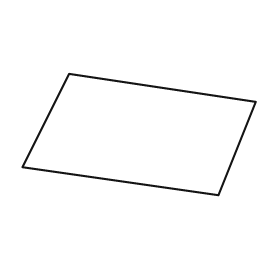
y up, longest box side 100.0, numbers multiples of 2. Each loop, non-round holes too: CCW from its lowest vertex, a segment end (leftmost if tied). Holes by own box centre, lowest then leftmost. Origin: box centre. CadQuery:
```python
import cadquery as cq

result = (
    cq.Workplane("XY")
    .moveTo(34.0, -26.0)
    .lineTo(50.0, 14.0)
    .lineTo(-30.0, 26.0)
    .lineTo(-50.0, -14.0)
    .close()
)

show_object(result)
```